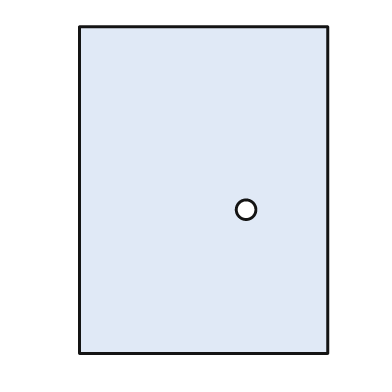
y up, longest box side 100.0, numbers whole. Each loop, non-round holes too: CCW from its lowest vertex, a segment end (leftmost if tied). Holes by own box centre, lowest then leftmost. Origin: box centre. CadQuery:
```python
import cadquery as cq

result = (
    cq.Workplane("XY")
    .moveTo(-38.0, -50.0)
    .lineTo(38.0, -50.0)
    .lineTo(38.0, 50.0)
    .lineTo(-38.0, 50.0)
    .close()
    .moveTo(13.0, -6.0)
    .circle(3.0)
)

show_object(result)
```